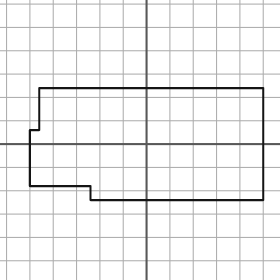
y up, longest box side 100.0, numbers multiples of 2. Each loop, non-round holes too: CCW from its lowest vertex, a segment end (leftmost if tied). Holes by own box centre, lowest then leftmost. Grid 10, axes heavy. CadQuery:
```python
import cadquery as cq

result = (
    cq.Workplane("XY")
    .moveTo(-24.0, -24.0)
    .lineTo(50.0, -24.0)
    .lineTo(50.0, 24.0)
    .lineTo(-46.0, 24.0)
    .lineTo(-46.0, 6.0)
    .lineTo(-50.0, 6.0)
    .lineTo(-50.0, -18.0)
    .lineTo(-24.0, -18.0)
    .close()
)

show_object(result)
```